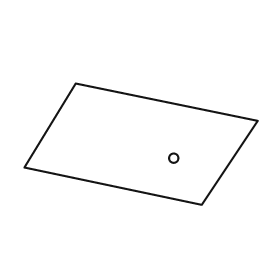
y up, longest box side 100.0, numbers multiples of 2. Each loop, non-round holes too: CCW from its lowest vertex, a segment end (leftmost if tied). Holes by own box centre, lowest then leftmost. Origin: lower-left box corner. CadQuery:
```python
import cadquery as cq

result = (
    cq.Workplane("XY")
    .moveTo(76.0, 0.0)
    .lineTo(100.0, 36.0)
    .lineTo(22.0, 52.0)
    .lineTo(0.0, 16.0)
    .close()
    .moveTo(64.0, 20.0)
    .circle(2.0)
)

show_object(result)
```